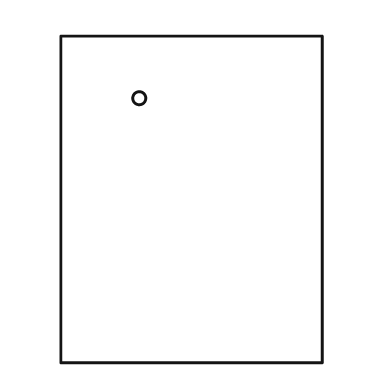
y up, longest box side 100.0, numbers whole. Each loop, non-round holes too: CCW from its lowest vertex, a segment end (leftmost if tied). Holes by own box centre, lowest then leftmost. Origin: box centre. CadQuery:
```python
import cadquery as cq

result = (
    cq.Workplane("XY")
    .moveTo(-40.0, -50.0)
    .lineTo(40.0, -50.0)
    .lineTo(40.0, 50.0)
    .lineTo(-40.0, 50.0)
    .close()
    .moveTo(-16.0, 31.0)
    .circle(2.0)
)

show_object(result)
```